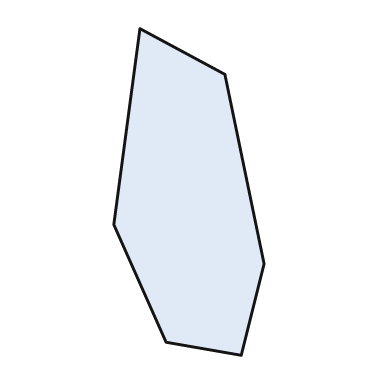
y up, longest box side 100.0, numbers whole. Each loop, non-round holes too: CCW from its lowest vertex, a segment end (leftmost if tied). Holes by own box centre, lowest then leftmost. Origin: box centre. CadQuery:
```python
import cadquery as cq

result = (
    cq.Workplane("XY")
    .moveTo(16.0, -50.0)
    .lineTo(23.0, -22.0)
    .lineTo(11.0, 36.0)
    .lineTo(-15.0, 50.0)
    .lineTo(-23.0, -10.0)
    .lineTo(-7.0, -46.0)
    .close()
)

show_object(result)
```